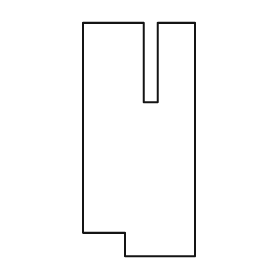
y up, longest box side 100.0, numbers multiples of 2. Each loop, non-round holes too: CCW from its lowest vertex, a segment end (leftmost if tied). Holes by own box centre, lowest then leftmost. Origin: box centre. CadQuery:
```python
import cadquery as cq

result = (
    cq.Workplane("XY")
    .moveTo(-6.0, -50.0)
    .lineTo(24.0, -50.0)
    .lineTo(24.0, 50.0)
    .lineTo(8.0, 50.0)
    .lineTo(8.0, 16.0)
    .lineTo(2.0, 16.0)
    .lineTo(2.0, 50.0)
    .lineTo(-24.0, 50.0)
    .lineTo(-24.0, -40.0)
    .lineTo(-6.0, -40.0)
    .close()
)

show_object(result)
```